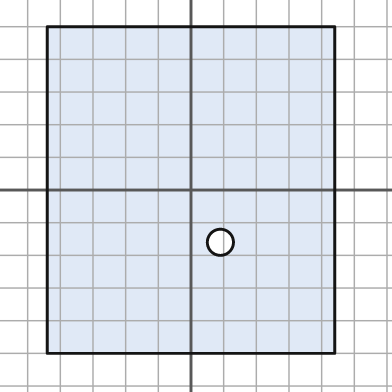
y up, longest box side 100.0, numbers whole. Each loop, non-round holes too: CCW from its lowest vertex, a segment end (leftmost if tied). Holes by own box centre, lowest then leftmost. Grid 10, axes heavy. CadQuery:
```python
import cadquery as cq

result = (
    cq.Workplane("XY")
    .moveTo(-44.0, -50.0)
    .lineTo(44.0, -50.0)
    .lineTo(44.0, 50.0)
    .lineTo(-44.0, 50.0)
    .close()
    .moveTo(9.0, -16.0)
    .circle(4.0)
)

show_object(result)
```